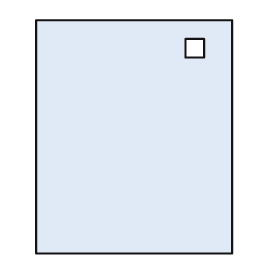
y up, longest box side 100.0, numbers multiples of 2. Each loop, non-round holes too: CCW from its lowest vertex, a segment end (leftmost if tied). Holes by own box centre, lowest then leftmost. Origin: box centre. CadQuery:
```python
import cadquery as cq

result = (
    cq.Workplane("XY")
    .moveTo(-42.0, -50.0)
    .lineTo(42.0, -50.0)
    .lineTo(42.0, 50.0)
    .lineTo(-42.0, 50.0)
    .close()
    .moveTo(22.0, 34.0)
    .lineTo(30.0, 34.0)
    .lineTo(30.0, 42.0)
    .lineTo(22.0, 42.0)
    .close()
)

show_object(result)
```